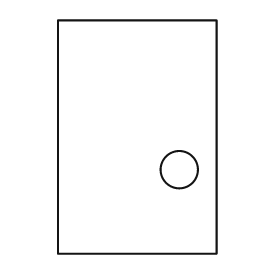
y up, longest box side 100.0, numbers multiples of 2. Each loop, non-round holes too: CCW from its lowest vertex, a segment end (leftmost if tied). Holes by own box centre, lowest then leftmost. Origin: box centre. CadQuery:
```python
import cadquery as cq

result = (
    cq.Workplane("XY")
    .moveTo(-34.0, -50.0)
    .lineTo(34.0, -50.0)
    .lineTo(34.0, 50.0)
    .lineTo(-34.0, 50.0)
    .close()
    .moveTo(18.0, -14.0)
    .circle(8.0)
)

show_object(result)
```